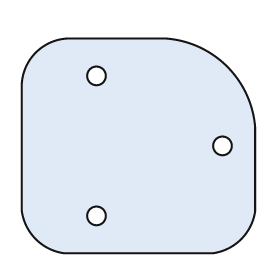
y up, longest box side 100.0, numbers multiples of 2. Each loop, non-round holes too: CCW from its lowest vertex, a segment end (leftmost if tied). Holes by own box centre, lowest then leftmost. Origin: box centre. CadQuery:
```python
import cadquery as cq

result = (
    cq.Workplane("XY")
    .moveTo(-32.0, -46.0)
    .lineTo(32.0, -46.0)
    .threePointArc((44.0, -40.0), (50.0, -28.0))
    .lineTo(50.0, 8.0)
    .threePointArc((38.0, 34.0), (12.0, 46.0))
    .lineTo(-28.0, 46.0)
    .threePointArc((-44.0, 40.0), (-50.0, 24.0))
    .lineTo(-50.0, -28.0)
    .threePointArc((-44.0, -40.0), (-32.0, -46.0))
    .close()
    .moveTo(-18.0, -30.0)
    .circle(4.0)
    .moveTo(36.0, 0.0)
    .circle(4.0)
    .moveTo(-18.0, 30.0)
    .circle(4.0)
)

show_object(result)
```